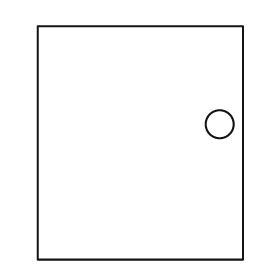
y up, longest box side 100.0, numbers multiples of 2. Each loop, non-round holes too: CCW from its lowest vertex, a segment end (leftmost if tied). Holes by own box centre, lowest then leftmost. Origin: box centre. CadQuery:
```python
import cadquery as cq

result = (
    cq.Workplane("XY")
    .moveTo(-44.0, -50.0)
    .lineTo(44.0, -50.0)
    .lineTo(44.0, 50.0)
    .lineTo(-44.0, 50.0)
    .close()
    .moveTo(34.0, 8.0)
    .circle(6.0)
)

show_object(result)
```